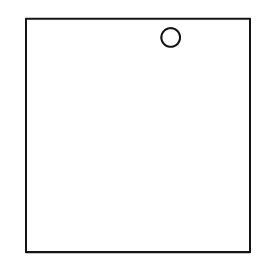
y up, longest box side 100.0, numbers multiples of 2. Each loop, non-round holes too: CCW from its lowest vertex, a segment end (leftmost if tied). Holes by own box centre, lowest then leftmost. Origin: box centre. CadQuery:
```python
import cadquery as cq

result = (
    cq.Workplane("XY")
    .moveTo(-48.0, -50.0)
    .lineTo(48.0, -50.0)
    .lineTo(48.0, 50.0)
    .lineTo(-48.0, 50.0)
    .close()
    .moveTo(14.0, 42.0)
    .circle(4.0)
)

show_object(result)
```